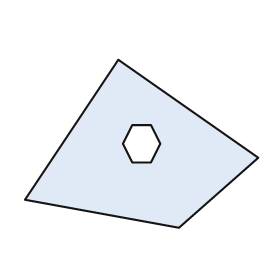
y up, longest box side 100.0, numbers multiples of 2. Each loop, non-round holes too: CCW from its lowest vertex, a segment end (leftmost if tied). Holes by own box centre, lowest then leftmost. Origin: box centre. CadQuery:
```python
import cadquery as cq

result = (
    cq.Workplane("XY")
    .moveTo(16.0, -36.0)
    .lineTo(50.0, -6.0)
    .lineTo(-10.0, 36.0)
    .lineTo(-50.0, -24.0)
    .close()
    .moveTo(-4.0, -8.0)
    .lineTo(4.0, -8.0)
    .lineTo(8.0, 0.0)
    .lineTo(4.0, 8.0)
    .lineTo(-4.0, 8.0)
    .lineTo(-8.0, 0.0)
    .close()
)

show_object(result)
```